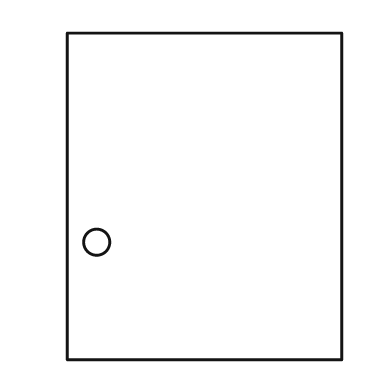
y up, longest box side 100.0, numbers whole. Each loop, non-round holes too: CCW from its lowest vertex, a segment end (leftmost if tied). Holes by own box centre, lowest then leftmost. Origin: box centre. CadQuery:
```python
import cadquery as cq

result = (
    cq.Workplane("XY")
    .moveTo(-42.0, -50.0)
    .lineTo(42.0, -50.0)
    .lineTo(42.0, 50.0)
    .lineTo(-42.0, 50.0)
    .close()
    .moveTo(-33.0, -14.0)
    .circle(4.0)
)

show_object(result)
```